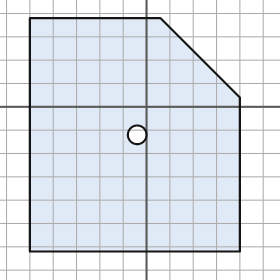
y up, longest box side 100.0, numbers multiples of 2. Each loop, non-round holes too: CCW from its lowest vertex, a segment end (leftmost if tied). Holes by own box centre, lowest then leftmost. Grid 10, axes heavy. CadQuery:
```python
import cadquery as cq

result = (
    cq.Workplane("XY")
    .moveTo(-50.0, -62.0)
    .lineTo(40.0, -62.0)
    .lineTo(40.0, 4.0)
    .lineTo(6.0, 38.0)
    .lineTo(-50.0, 38.0)
    .close()
    .moveTo(-4.0, -12.0)
    .circle(4.0)
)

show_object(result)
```